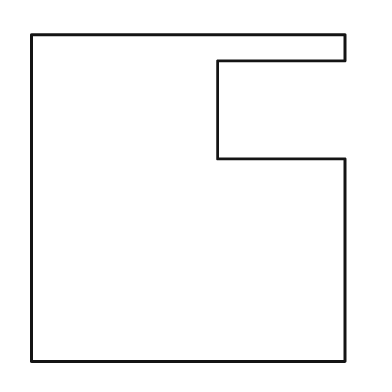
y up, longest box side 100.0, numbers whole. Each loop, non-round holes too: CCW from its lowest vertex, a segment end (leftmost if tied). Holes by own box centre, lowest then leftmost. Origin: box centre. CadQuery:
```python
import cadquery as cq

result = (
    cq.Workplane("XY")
    .moveTo(-48.0, -50.0)
    .lineTo(48.0, -50.0)
    .lineTo(48.0, 12.0)
    .lineTo(9.0, 12.0)
    .lineTo(9.0, 42.0)
    .lineTo(48.0, 42.0)
    .lineTo(48.0, 50.0)
    .lineTo(-48.0, 50.0)
    .close()
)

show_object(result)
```